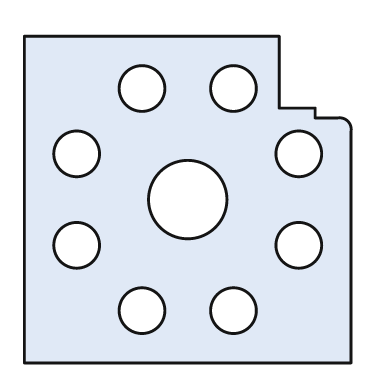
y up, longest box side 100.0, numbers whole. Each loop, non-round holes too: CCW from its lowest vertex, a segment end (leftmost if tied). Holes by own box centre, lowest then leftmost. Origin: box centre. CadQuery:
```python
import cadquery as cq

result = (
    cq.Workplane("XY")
    .moveTo(-50.0, -50.0)
    .lineTo(50.0, -50.0)
    .lineTo(50.0, 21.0)
    .threePointArc((49.0, 24.0), (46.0, 25.0))
    .lineTo(39.0, 25.0)
    .lineTo(39.0, 28.0)
    .lineTo(28.0, 28.0)
    .lineTo(28.0, 50.0)
    .lineTo(-50.0, 50.0)
    .close()
    .moveTo(-14.0, -34.0)
    .circle(7.0)
    .moveTo(14.0, -34.0)
    .circle(7.0)
    .moveTo(-34.0, -14.0)
    .circle(7.0)
    .moveTo(34.0, -14.0)
    .circle(7.0)
    .moveTo(0.0, 0.0)
    .circle(12.0)
    .moveTo(-34.0, 14.0)
    .circle(7.0)
    .moveTo(34.0, 14.0)
    .circle(7.0)
    .moveTo(-14.0, 34.0)
    .circle(7.0)
    .moveTo(14.0, 34.0)
    .circle(7.0)
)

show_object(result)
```